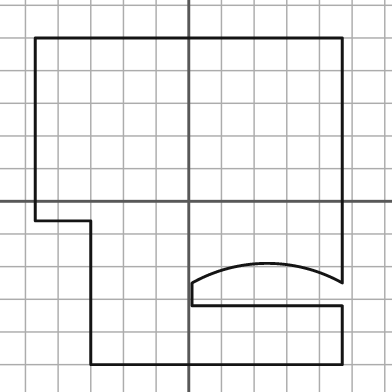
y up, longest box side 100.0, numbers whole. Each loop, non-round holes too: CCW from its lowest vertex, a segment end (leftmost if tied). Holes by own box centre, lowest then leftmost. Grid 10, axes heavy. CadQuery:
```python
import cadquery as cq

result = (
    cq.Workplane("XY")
    .moveTo(-30.0, -50.0)
    .lineTo(47.0, -50.0)
    .lineTo(47.0, -32.0)
    .lineTo(1.0, -32.0)
    .lineTo(1.0, -25.0)
    .threePointArc((24.0, -19.0), (47.0, -25.0))
    .lineTo(47.0, 50.0)
    .lineTo(-47.0, 50.0)
    .lineTo(-47.0, -6.0)
    .lineTo(-30.0, -6.0)
    .close()
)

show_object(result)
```